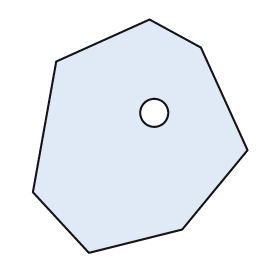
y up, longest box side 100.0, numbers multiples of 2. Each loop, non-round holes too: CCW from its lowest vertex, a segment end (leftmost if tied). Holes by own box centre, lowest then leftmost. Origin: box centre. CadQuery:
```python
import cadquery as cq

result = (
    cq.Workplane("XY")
    .moveTo(-22.0, -50.0)
    .lineTo(18.0, -40.0)
    .lineTo(46.0, -6.0)
    .lineTo(26.0, 38.0)
    .lineTo(4.0, 50.0)
    .lineTo(-36.0, 32.0)
    .lineTo(-46.0, -24.0)
    .close()
    .moveTo(6.0, 10.0)
    .circle(6.0)
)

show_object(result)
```